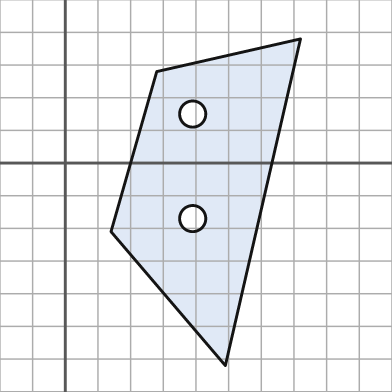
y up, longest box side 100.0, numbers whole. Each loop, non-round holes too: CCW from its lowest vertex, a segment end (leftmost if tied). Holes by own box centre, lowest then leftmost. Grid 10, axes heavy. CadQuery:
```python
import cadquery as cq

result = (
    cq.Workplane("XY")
    .moveTo(49.0, -62.0)
    .lineTo(72.0, 38.0)
    .lineTo(28.0, 28.0)
    .lineTo(14.0, -21.0)
    .close()
    .moveTo(39.0, -17.0)
    .circle(4.0)
    .moveTo(39.0, 15.0)
    .circle(4.0)
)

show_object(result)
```